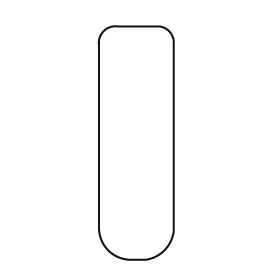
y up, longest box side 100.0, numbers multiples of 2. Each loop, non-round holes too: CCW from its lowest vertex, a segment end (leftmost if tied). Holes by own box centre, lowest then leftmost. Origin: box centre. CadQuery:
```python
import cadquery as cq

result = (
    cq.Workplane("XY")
    .moveTo(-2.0, -50.0)
    .lineTo(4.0, -50.0)
    .threePointArc((12.0, -46.0), (16.0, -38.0))
    .lineTo(16.0, 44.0)
    .threePointArc((14.0, 48.0), (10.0, 50.0))
    .lineTo(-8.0, 50.0)
    .threePointArc((-14.0, 48.0), (-16.0, 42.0))
    .lineTo(-16.0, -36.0)
    .threePointArc((-12.0, -46.0), (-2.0, -50.0))
    .close()
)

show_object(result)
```